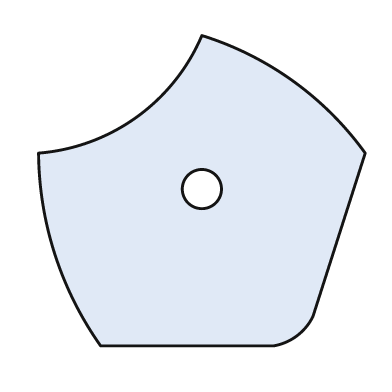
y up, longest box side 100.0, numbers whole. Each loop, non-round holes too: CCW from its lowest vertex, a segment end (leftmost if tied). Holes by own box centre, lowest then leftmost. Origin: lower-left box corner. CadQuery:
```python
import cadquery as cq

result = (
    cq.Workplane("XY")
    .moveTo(19.0, 0.0)
    .lineTo(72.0, 0.0)
    .threePointArc((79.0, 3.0), (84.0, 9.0))
    .lineTo(100.0, 59.0)
    .threePointArc((78.0, 81.0), (50.0, 95.0))
    .threePointArc((30.0, 70.0), (0.0, 59.0))
    .threePointArc((5.0, 28.0), (19.0, 0.0))
    .close()
    .moveTo(50.0, 48.0)
    .circle(6.0)
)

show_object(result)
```